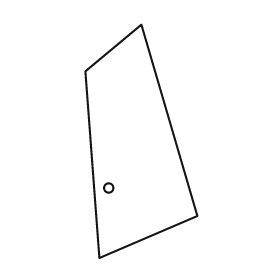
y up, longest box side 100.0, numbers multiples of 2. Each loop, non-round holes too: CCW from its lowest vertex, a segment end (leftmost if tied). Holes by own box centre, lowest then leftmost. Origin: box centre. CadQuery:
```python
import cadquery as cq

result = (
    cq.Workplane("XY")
    .moveTo(-18.0, -50.0)
    .lineTo(24.0, -32.0)
    .lineTo(0.0, 50.0)
    .lineTo(-24.0, 30.0)
    .close()
    .moveTo(-14.0, -20.0)
    .circle(2.0)
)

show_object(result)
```